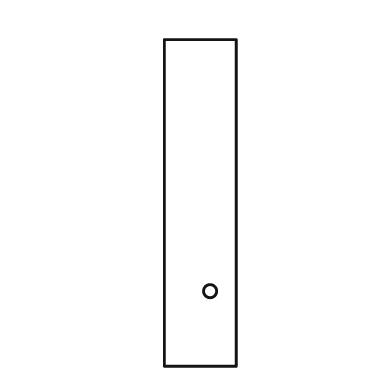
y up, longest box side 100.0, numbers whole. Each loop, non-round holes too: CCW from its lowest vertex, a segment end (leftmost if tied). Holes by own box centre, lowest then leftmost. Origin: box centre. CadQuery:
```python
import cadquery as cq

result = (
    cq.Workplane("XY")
    .moveTo(-11.0, -50.0)
    .lineTo(11.0, -50.0)
    .lineTo(11.0, 50.0)
    .lineTo(-11.0, 50.0)
    .close()
    .moveTo(3.0, -27.0)
    .circle(2.0)
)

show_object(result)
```